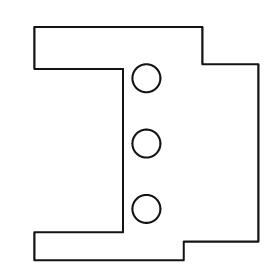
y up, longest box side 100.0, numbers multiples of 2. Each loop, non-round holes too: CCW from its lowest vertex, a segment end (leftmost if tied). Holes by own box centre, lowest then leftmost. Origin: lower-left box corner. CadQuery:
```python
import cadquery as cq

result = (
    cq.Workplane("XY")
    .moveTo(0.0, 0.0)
    .lineTo(64.0, 0.0)
    .lineTo(64.0, 8.0)
    .lineTo(96.0, 8.0)
    .lineTo(96.0, 84.0)
    .lineTo(72.0, 84.0)
    .lineTo(72.0, 100.0)
    .lineTo(0.0, 100.0)
    .lineTo(0.0, 82.0)
    .lineTo(38.0, 82.0)
    .lineTo(38.0, 12.0)
    .lineTo(0.0, 12.0)
    .close()
    .moveTo(48.0, 22.0)
    .circle(6.0)
    .moveTo(48.0, 50.0)
    .circle(6.0)
    .moveTo(48.0, 78.0)
    .circle(6.0)
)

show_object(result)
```